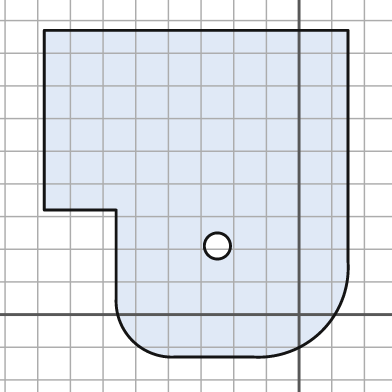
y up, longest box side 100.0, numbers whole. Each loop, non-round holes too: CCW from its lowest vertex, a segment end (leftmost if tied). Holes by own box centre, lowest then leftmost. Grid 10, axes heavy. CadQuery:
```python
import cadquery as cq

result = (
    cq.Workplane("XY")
    .moveTo(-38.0, -13.0)
    .lineTo(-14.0, -13.0)
    .threePointArc((7.0, -5.0), (15.0, 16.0))
    .lineTo(15.0, 87.0)
    .lineTo(-78.0, 87.0)
    .lineTo(-78.0, 32.0)
    .lineTo(-56.0, 32.0)
    .lineTo(-56.0, 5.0)
    .threePointArc((-51.0, -8.0), (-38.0, -13.0))
    .close()
    .moveTo(-25.0, 21.0)
    .circle(4.0)
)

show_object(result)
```